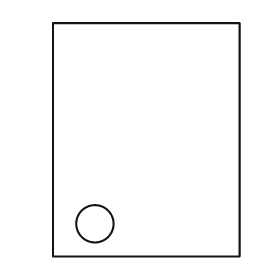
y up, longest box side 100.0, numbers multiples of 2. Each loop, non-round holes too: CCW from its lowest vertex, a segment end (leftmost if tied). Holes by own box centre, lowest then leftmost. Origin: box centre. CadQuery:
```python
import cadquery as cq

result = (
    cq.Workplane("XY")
    .moveTo(-40.0, -50.0)
    .lineTo(40.0, -50.0)
    .lineTo(40.0, 50.0)
    .lineTo(-40.0, 50.0)
    .close()
    .moveTo(-22.0, -36.0)
    .circle(8.0)
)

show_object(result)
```